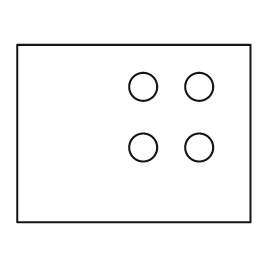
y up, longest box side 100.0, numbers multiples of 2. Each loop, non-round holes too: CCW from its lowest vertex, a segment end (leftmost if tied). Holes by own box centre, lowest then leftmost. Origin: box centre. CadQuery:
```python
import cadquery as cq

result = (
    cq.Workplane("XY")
    .moveTo(-50.0, -38.0)
    .lineTo(50.0, -38.0)
    .lineTo(50.0, 38.0)
    .lineTo(-50.0, 38.0)
    .close()
    .moveTo(4.0, -6.0)
    .circle(6.0)
    .moveTo(28.0, -6.0)
    .circle(6.0)
    .moveTo(4.0, 20.0)
    .circle(6.0)
    .moveTo(28.0, 20.0)
    .circle(6.0)
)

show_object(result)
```